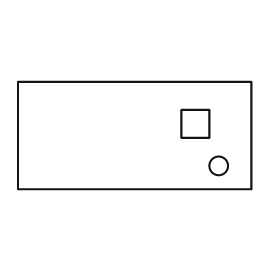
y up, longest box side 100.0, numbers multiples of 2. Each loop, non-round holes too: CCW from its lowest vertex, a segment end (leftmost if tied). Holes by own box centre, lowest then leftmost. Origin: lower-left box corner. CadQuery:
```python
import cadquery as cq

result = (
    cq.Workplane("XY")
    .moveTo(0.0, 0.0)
    .lineTo(100.0, 0.0)
    .lineTo(100.0, 46.0)
    .lineTo(0.0, 46.0)
    .close()
    .moveTo(86.0, 10.0)
    .circle(4.0)
    .moveTo(70.0, 22.0)
    .lineTo(82.0, 22.0)
    .lineTo(82.0, 34.0)
    .lineTo(70.0, 34.0)
    .close()
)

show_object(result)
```